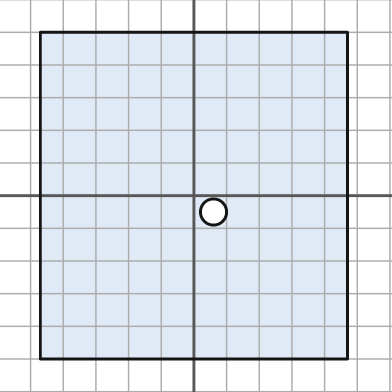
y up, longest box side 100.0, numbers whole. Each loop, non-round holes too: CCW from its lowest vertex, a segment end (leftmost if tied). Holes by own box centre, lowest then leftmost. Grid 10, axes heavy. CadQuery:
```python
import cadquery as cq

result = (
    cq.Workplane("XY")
    .moveTo(-47.0, -50.0)
    .lineTo(47.0, -50.0)
    .lineTo(47.0, 50.0)
    .lineTo(-47.0, 50.0)
    .close()
    .moveTo(6.0, -5.0)
    .circle(4.0)
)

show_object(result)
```